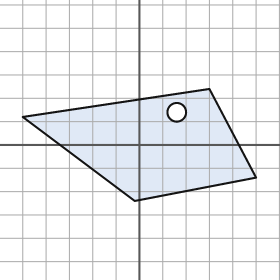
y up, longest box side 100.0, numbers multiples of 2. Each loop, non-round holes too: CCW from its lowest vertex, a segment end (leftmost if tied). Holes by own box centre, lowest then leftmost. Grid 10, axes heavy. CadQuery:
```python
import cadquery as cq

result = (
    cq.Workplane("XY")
    .moveTo(-2.0, -24.0)
    .lineTo(50.0, -14.0)
    .lineTo(30.0, 24.0)
    .lineTo(-50.0, 12.0)
    .close()
    .moveTo(16.0, 14.0)
    .circle(4.0)
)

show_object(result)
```